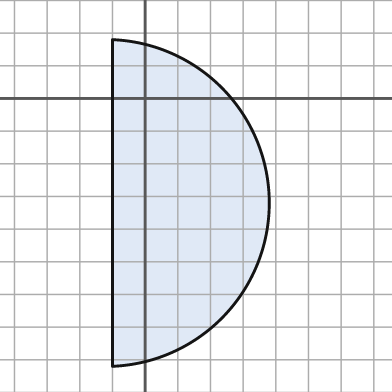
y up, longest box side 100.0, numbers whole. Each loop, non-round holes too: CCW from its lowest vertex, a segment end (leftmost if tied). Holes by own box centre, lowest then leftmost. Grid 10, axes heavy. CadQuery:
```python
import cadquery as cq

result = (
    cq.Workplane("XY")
    .moveTo(-10.0, -82.0)
    .threePointArc((38.0, -32.0), (-10.0, 18.0))
    .close()
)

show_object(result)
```